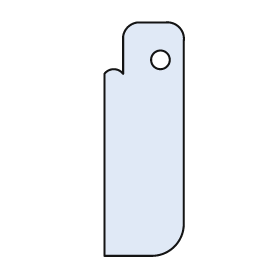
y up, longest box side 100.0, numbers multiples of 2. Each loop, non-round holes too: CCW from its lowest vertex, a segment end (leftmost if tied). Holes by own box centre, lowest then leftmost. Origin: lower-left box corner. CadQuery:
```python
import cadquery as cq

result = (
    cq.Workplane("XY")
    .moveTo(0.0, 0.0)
    .lineTo(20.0, 0.0)
    .threePointArc((30.0, 4.0), (34.0, 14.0))
    .lineTo(34.0, 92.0)
    .threePointArc((32.0, 98.0), (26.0, 100.0))
    .lineTo(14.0, 100.0)
    .threePointArc((10.0, 98.0), (8.0, 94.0))
    .lineTo(8.0, 78.0)
    .threePointArc((4.0, 80.0), (0.0, 78.0))
    .close()
    .moveTo(24.0, 84.0)
    .circle(4.0)
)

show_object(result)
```